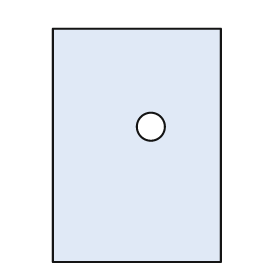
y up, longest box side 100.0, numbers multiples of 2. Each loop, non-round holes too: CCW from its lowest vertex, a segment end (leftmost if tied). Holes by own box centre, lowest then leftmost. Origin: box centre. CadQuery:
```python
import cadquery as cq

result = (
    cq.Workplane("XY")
    .moveTo(-36.0, -50.0)
    .lineTo(36.0, -50.0)
    .lineTo(36.0, 50.0)
    .lineTo(-36.0, 50.0)
    .close()
    .moveTo(6.0, 8.0)
    .circle(6.0)
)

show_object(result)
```